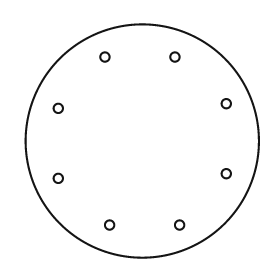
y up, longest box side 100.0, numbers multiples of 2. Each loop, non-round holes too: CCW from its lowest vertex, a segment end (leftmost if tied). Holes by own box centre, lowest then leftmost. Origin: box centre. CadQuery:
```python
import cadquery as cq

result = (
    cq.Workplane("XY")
    .moveTo(0.0, 0.0)
    .circle(50.0)
    .moveTo(-14.0, -36.0)
    .circle(2.0)
    .moveTo(16.0, -36.0)
    .circle(2.0)
    .moveTo(-36.0, -16.0)
    .circle(2.0)
    .moveTo(36.0, -14.0)
    .circle(2.0)
    .moveTo(-36.0, 14.0)
    .circle(2.0)
    .moveTo(36.0, 16.0)
    .circle(2.0)
    .moveTo(-16.0, 36.0)
    .circle(2.0)
    .moveTo(14.0, 36.0)
    .circle(2.0)
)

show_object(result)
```